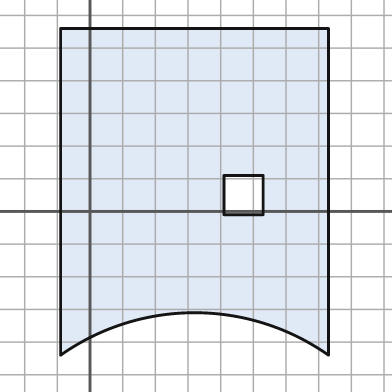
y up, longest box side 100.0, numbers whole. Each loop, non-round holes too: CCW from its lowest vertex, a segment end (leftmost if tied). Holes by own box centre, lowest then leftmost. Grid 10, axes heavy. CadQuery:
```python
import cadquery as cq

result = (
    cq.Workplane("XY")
    .moveTo(-9.0, -44.0)
    .threePointArc((32.0, -31.0), (73.0, -44.0))
    .lineTo(73.0, 56.0)
    .lineTo(-9.0, 56.0)
    .close()
    .moveTo(41.0, -1.0)
    .lineTo(53.0, -1.0)
    .lineTo(53.0, 11.0)
    .lineTo(41.0, 11.0)
    .close()
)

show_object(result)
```